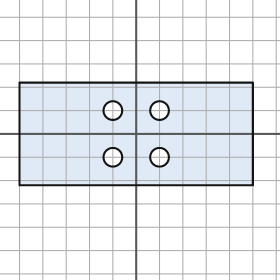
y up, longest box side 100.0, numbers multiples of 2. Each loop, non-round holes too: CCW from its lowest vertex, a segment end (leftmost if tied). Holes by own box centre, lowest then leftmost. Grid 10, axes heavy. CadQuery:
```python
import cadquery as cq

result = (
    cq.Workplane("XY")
    .moveTo(-50.0, -22.0)
    .lineTo(50.0, -22.0)
    .lineTo(50.0, 22.0)
    .lineTo(-50.0, 22.0)
    .close()
    .moveTo(-10.0, -10.0)
    .circle(4.0)
    .moveTo(10.0, -10.0)
    .circle(4.0)
    .moveTo(-10.0, 10.0)
    .circle(4.0)
    .moveTo(10.0, 10.0)
    .circle(4.0)
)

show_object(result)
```